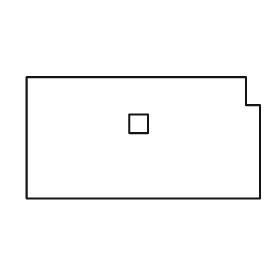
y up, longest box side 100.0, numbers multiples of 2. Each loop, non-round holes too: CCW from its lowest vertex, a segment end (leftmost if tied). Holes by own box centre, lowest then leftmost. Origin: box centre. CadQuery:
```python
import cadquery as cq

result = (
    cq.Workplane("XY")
    .moveTo(-50.0, -26.0)
    .lineTo(50.0, -26.0)
    .lineTo(50.0, 14.0)
    .lineTo(44.0, 14.0)
    .lineTo(44.0, 26.0)
    .lineTo(-50.0, 26.0)
    .close()
    .moveTo(-6.0, 2.0)
    .lineTo(2.0, 2.0)
    .lineTo(2.0, 10.0)
    .lineTo(-6.0, 10.0)
    .close()
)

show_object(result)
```